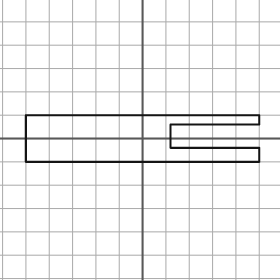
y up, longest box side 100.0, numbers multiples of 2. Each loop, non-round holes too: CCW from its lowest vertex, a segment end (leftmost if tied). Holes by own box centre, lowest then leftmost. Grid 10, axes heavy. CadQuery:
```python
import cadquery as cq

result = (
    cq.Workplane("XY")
    .moveTo(-50.0, -10.0)
    .lineTo(50.0, -10.0)
    .lineTo(50.0, -4.0)
    .lineTo(12.0, -4.0)
    .lineTo(12.0, 6.0)
    .lineTo(50.0, 6.0)
    .lineTo(50.0, 10.0)
    .lineTo(-50.0, 10.0)
    .close()
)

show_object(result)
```